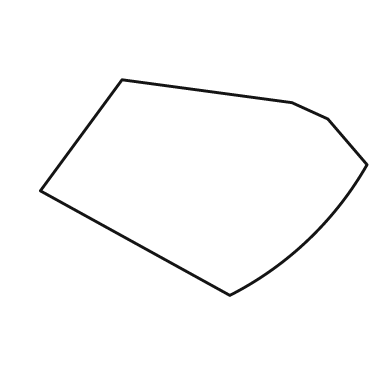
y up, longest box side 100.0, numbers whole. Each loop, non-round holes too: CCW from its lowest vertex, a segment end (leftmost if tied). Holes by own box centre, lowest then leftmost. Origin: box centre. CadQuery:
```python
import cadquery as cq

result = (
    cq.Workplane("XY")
    .moveTo(8.0, -33.0)
    .threePointArc((32.0, -16.0), (50.0, 7.0))
    .lineTo(38.0, 21.0)
    .lineTo(27.0, 26.0)
    .lineTo(-25.0, 33.0)
    .lineTo(-50.0, -1.0)
    .close()
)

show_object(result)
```